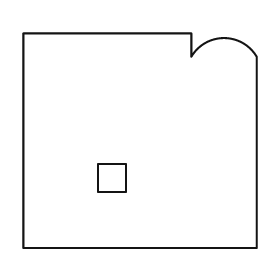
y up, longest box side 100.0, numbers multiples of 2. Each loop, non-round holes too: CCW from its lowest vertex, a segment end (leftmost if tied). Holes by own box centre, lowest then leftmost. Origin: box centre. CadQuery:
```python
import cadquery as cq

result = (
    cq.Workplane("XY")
    .moveTo(-50.0, -46.0)
    .lineTo(50.0, -46.0)
    .lineTo(50.0, 36.0)
    .threePointArc((36.0, 44.0), (22.0, 36.0))
    .lineTo(22.0, 46.0)
    .lineTo(-50.0, 46.0)
    .close()
    .moveTo(-18.0, -22.0)
    .lineTo(-6.0, -22.0)
    .lineTo(-6.0, -10.0)
    .lineTo(-18.0, -10.0)
    .close()
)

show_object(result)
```